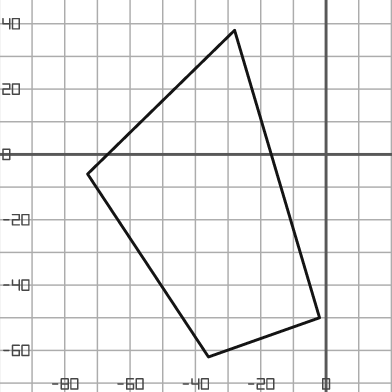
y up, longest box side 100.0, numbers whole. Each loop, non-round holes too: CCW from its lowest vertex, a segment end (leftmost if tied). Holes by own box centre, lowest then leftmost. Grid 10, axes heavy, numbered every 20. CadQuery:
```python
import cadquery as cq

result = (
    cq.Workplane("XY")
    .moveTo(-36.0, -62.0)
    .lineTo(-2.0, -50.0)
    .lineTo(-28.0, 38.0)
    .lineTo(-73.0, -6.0)
    .close()
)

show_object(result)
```